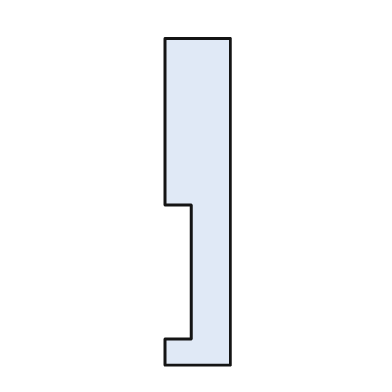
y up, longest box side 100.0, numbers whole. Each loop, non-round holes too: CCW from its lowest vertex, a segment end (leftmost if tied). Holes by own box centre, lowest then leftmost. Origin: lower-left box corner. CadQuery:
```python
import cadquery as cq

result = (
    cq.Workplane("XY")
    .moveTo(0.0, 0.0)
    .lineTo(20.0, 0.0)
    .lineTo(20.0, 100.0)
    .lineTo(0.0, 100.0)
    .lineTo(0.0, 49.0)
    .lineTo(8.0, 49.0)
    .lineTo(8.0, 8.0)
    .lineTo(0.0, 8.0)
    .close()
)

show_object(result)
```